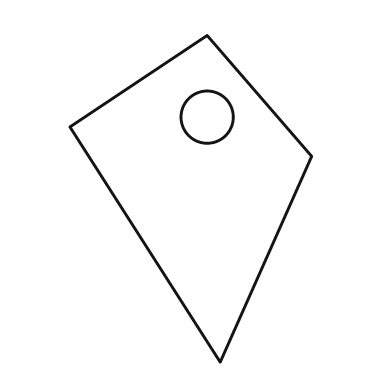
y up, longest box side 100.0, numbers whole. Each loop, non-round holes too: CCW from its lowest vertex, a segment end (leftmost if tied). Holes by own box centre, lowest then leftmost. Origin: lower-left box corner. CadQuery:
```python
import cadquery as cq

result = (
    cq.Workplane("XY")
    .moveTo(46.0, 0.0)
    .lineTo(74.0, 63.0)
    .lineTo(42.0, 100.0)
    .lineTo(0.0, 72.0)
    .close()
    .moveTo(42.0, 75.0)
    .circle(8.0)
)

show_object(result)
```